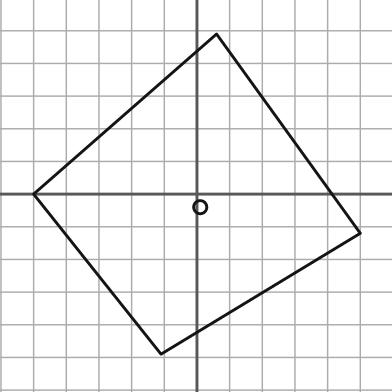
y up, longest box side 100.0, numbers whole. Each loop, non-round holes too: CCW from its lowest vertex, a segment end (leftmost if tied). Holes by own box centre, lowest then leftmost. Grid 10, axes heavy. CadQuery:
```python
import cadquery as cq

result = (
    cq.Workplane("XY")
    .moveTo(-11.0, -49.0)
    .lineTo(50.0, -12.0)
    .lineTo(6.0, 49.0)
    .lineTo(-50.0, 0.0)
    .close()
    .moveTo(1.0, -4.0)
    .circle(2.0)
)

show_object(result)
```